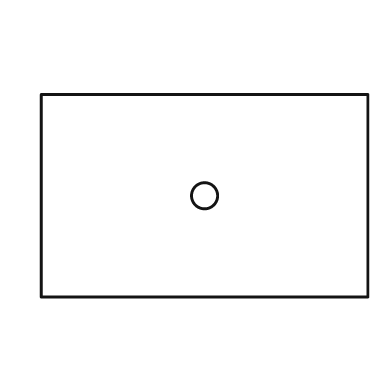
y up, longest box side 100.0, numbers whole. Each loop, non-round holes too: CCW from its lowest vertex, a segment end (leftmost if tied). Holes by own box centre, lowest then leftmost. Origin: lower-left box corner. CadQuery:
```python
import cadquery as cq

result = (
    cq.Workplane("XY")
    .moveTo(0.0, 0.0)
    .lineTo(100.0, 0.0)
    .lineTo(100.0, 62.0)
    .lineTo(0.0, 62.0)
    .close()
    .moveTo(50.0, 31.0)
    .circle(4.0)
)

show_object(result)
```